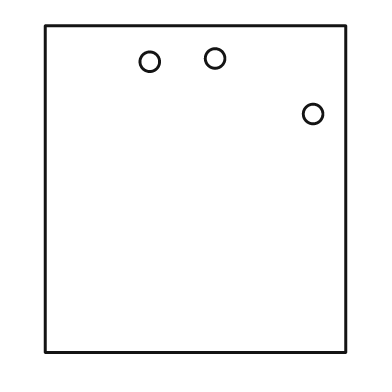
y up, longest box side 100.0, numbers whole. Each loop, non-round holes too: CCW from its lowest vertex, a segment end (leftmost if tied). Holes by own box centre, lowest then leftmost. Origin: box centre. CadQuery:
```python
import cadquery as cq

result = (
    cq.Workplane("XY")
    .moveTo(-46.0, -50.0)
    .lineTo(46.0, -50.0)
    .lineTo(46.0, 50.0)
    .lineTo(-46.0, 50.0)
    .close()
    .moveTo(36.0, 23.0)
    .circle(3.0)
    .moveTo(-14.0, 39.0)
    .circle(3.0)
    .moveTo(6.0, 40.0)
    .circle(3.0)
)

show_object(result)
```